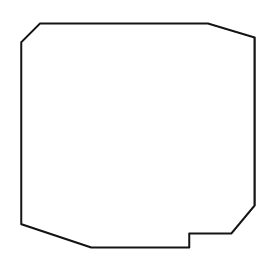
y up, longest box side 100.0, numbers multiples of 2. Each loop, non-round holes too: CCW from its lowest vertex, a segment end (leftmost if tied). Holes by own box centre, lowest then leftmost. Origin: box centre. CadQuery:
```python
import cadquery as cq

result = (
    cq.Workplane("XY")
    .moveTo(-20.0, -48.0)
    .lineTo(22.0, -48.0)
    .lineTo(22.0, -42.0)
    .lineTo(40.0, -42.0)
    .lineTo(50.0, -30.0)
    .lineTo(50.0, 42.0)
    .lineTo(30.0, 48.0)
    .lineTo(-42.0, 48.0)
    .lineTo(-50.0, 40.0)
    .lineTo(-50.0, -38.0)
    .close()
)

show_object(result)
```